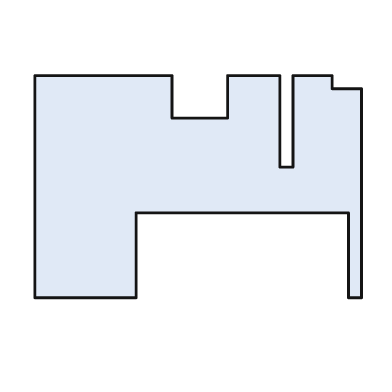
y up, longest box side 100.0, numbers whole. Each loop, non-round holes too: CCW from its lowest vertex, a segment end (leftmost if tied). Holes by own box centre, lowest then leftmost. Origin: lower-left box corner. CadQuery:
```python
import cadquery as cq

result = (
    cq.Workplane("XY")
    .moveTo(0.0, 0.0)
    .lineTo(31.0, 0.0)
    .lineTo(31.0, 26.0)
    .lineTo(96.0, 26.0)
    .lineTo(96.0, 0.0)
    .lineTo(100.0, 0.0)
    .lineTo(100.0, 64.0)
    .lineTo(91.0, 64.0)
    .lineTo(91.0, 68.0)
    .lineTo(79.0, 68.0)
    .lineTo(79.0, 40.0)
    .lineTo(75.0, 40.0)
    .lineTo(75.0, 68.0)
    .lineTo(59.0, 68.0)
    .lineTo(59.0, 55.0)
    .lineTo(42.0, 55.0)
    .lineTo(42.0, 68.0)
    .lineTo(0.0, 68.0)
    .close()
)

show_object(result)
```